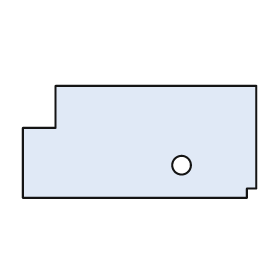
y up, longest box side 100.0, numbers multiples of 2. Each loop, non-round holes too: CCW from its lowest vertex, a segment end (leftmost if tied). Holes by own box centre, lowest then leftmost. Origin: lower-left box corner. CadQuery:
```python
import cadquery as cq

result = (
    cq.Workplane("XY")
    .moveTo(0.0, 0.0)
    .lineTo(96.0, 0.0)
    .lineTo(96.0, 4.0)
    .lineTo(100.0, 4.0)
    .lineTo(100.0, 48.0)
    .lineTo(14.0, 48.0)
    .lineTo(14.0, 30.0)
    .lineTo(0.0, 30.0)
    .close()
    .moveTo(68.0, 14.0)
    .circle(4.0)
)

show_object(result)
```